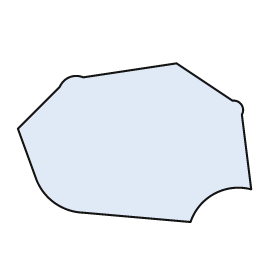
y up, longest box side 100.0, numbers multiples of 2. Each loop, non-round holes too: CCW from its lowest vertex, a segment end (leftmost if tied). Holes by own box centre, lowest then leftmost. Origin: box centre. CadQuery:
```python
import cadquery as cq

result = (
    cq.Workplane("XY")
    .moveTo(24.0, -34.0)
    .threePointArc((34.0, -22.0), (50.0, -20.0))
    .lineTo(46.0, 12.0)
    .threePointArc((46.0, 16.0), (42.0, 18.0))
    .lineTo(18.0, 34.0)
    .lineTo(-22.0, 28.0)
    .threePointArc((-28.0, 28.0), (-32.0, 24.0))
    .lineTo(-50.0, 6.0)
    .lineTo(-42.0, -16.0)
    .threePointArc((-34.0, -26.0), (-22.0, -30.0))
    .close()
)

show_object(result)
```